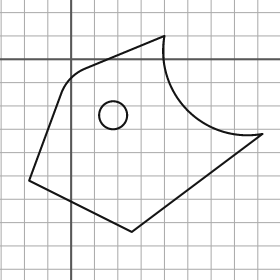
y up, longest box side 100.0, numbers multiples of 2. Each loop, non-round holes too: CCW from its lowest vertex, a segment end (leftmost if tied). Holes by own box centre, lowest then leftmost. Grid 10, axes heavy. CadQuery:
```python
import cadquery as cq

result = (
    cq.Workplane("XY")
    .moveTo(26.0, -74.0)
    .lineTo(82.0, -32.0)
    .threePointArc((50.0, -22.0), (40.0, 10.0))
    .lineTo(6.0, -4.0)
    .threePointArc((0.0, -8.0), (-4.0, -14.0))
    .lineTo(-18.0, -52.0)
    .close()
    .moveTo(18.0, -24.0)
    .circle(6.0)
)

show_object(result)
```